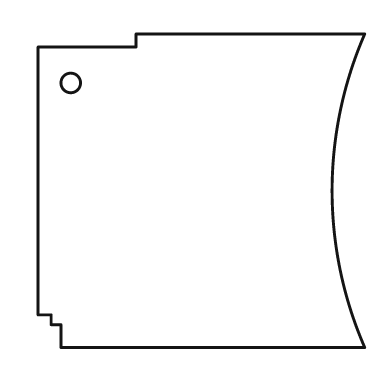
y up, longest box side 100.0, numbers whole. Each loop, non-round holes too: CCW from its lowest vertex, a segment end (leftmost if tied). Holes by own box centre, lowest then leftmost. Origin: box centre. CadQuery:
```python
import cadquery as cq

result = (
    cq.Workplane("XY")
    .moveTo(-43.0, -48.0)
    .lineTo(50.0, -48.0)
    .threePointArc((40.0, 0.0), (50.0, 48.0))
    .lineTo(-20.0, 48.0)
    .lineTo(-20.0, 44.0)
    .lineTo(-50.0, 44.0)
    .lineTo(-50.0, -38.0)
    .lineTo(-46.0, -38.0)
    .lineTo(-46.0, -41.0)
    .lineTo(-43.0, -41.0)
    .close()
    .moveTo(-40.0, 33.0)
    .circle(3.0)
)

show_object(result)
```